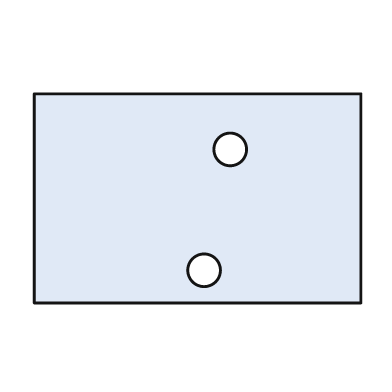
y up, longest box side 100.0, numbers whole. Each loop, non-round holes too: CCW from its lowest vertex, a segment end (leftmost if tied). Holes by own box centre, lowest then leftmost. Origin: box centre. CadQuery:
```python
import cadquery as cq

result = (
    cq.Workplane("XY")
    .moveTo(-50.0, -32.0)
    .lineTo(50.0, -32.0)
    .lineTo(50.0, 32.0)
    .lineTo(-50.0, 32.0)
    .close()
    .moveTo(2.0, -22.0)
    .circle(5.0)
    .moveTo(10.0, 15.0)
    .circle(5.0)
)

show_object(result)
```